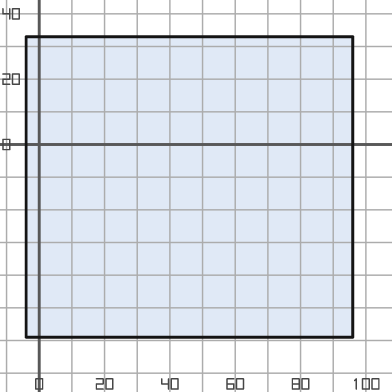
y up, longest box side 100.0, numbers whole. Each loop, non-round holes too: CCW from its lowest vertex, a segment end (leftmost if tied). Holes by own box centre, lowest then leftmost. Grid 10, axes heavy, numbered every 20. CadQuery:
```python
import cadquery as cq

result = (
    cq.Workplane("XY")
    .moveTo(-4.0, -59.0)
    .lineTo(96.0, -59.0)
    .lineTo(96.0, 33.0)
    .lineTo(-4.0, 33.0)
    .close()
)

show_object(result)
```